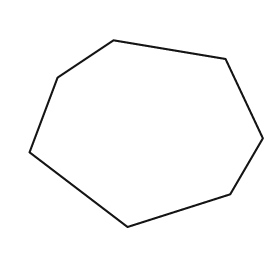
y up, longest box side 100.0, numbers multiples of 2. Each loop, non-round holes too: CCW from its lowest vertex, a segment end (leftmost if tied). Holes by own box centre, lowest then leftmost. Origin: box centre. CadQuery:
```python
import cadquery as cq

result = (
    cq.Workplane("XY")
    .moveTo(-8.0, -40.0)
    .lineTo(36.0, -26.0)
    .lineTo(50.0, -2.0)
    .lineTo(34.0, 32.0)
    .lineTo(-14.0, 40.0)
    .lineTo(-38.0, 24.0)
    .lineTo(-50.0, -8.0)
    .close()
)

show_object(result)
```